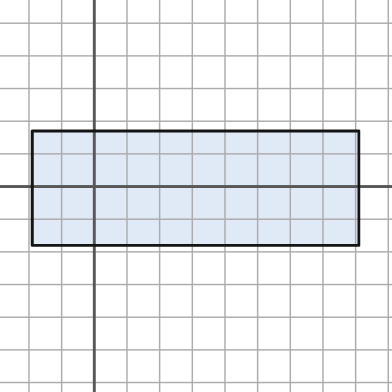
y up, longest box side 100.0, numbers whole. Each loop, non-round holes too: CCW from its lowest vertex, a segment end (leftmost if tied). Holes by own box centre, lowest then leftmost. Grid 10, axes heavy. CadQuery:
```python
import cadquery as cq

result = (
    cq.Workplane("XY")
    .moveTo(-19.0, -18.0)
    .lineTo(81.0, -18.0)
    .lineTo(81.0, 17.0)
    .lineTo(-19.0, 17.0)
    .close()
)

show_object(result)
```